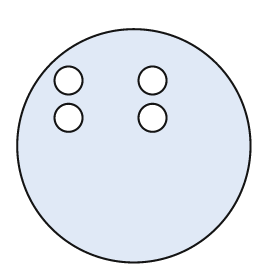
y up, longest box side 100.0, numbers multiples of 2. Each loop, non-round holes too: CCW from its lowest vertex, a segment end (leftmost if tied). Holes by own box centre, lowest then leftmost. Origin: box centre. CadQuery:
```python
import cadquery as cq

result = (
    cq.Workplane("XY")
    .moveTo(0.0, 0.0)
    .circle(50.0)
    .moveTo(-28.0, 12.0)
    .circle(6.0)
    .moveTo(8.0, 12.0)
    .circle(6.0)
    .moveTo(-28.0, 28.0)
    .circle(6.0)
    .moveTo(8.0, 28.0)
    .circle(6.0)
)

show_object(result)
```